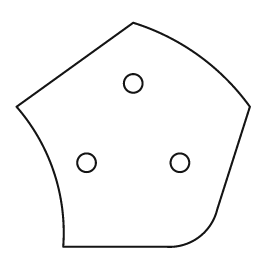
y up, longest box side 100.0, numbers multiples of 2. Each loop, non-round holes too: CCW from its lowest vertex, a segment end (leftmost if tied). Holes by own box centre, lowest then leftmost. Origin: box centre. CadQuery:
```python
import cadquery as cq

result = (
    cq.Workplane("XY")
    .moveTo(-30.0, -48.0)
    .lineTo(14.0, -48.0)
    .threePointArc((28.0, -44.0), (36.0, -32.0))
    .lineTo(50.0, 12.0)
    .threePointArc((28.0, 34.0), (0.0, 48.0))
    .lineTo(-50.0, 12.0)
    .threePointArc((-34.0, -16.0), (-30.0, -48.0))
    .close()
    .moveTo(-20.0, -12.0)
    .circle(4.0)
    .moveTo(20.0, -12.0)
    .circle(4.0)
    .moveTo(0.0, 22.0)
    .circle(4.0)
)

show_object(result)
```